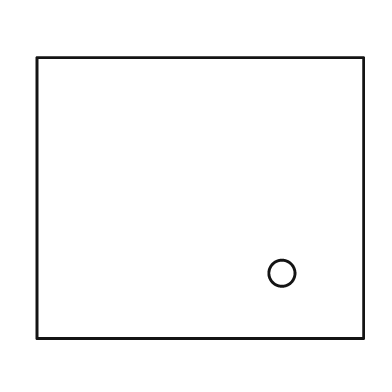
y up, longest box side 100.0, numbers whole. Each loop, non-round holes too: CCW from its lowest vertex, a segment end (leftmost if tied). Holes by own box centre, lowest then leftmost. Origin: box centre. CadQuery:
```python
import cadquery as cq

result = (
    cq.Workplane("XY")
    .moveTo(-50.0, -43.0)
    .lineTo(50.0, -43.0)
    .lineTo(50.0, 43.0)
    .lineTo(-50.0, 43.0)
    .close()
    .moveTo(25.0, -23.0)
    .circle(4.0)
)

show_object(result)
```